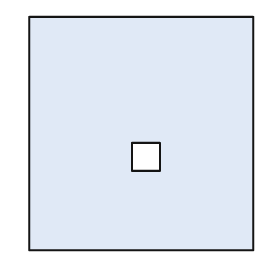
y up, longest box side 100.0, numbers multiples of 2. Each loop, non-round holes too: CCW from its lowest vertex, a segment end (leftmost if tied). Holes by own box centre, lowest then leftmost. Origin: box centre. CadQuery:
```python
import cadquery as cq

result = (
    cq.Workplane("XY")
    .moveTo(-48.0, -50.0)
    .lineTo(48.0, -50.0)
    .lineTo(48.0, 50.0)
    .lineTo(-48.0, 50.0)
    .close()
    .moveTo(-4.0, -16.0)
    .lineTo(8.0, -16.0)
    .lineTo(8.0, -4.0)
    .lineTo(-4.0, -4.0)
    .close()
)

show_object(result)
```